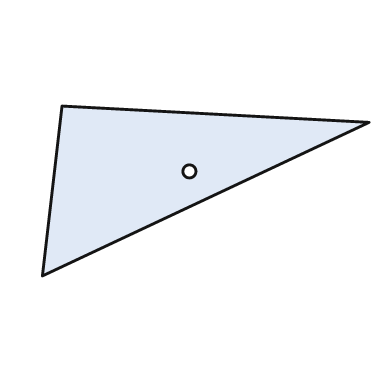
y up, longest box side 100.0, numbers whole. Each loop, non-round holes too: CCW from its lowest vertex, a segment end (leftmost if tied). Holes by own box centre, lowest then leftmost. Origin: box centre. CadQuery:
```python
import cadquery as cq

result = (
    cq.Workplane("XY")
    .moveTo(-50.0, -26.0)
    .lineTo(50.0, 21.0)
    .lineTo(-44.0, 26.0)
    .close()
    .moveTo(-5.0, 6.0)
    .circle(2.0)
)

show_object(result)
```